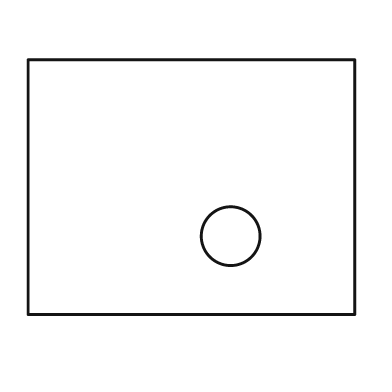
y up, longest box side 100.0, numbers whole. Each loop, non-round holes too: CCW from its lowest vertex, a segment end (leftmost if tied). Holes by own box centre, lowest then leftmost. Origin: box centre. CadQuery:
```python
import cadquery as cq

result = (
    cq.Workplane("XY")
    .moveTo(-50.0, -39.0)
    .lineTo(50.0, -39.0)
    .lineTo(50.0, 39.0)
    .lineTo(-50.0, 39.0)
    .close()
    .moveTo(12.0, -15.0)
    .circle(9.0)
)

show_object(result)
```